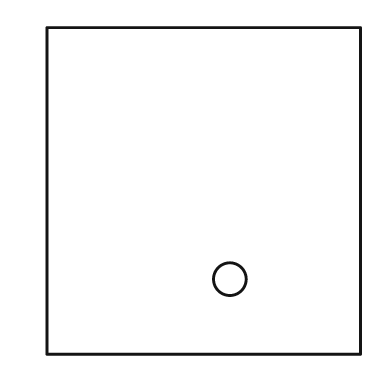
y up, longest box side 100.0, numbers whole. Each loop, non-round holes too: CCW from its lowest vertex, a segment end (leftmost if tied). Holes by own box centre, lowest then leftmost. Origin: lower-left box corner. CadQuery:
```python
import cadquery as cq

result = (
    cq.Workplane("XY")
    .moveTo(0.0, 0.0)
    .lineTo(96.0, 0.0)
    .lineTo(96.0, 100.0)
    .lineTo(0.0, 100.0)
    .close()
    .moveTo(56.0, 23.0)
    .circle(5.0)
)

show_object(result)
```